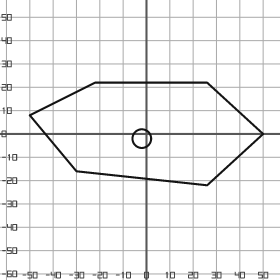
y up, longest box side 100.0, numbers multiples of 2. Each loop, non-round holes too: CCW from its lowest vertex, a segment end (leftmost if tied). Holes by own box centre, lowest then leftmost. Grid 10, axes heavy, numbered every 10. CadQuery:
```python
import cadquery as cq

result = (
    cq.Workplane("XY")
    .moveTo(26.0, -22.0)
    .lineTo(50.0, 0.0)
    .lineTo(26.0, 22.0)
    .lineTo(-22.0, 22.0)
    .lineTo(-50.0, 8.0)
    .lineTo(-30.0, -16.0)
    .close()
    .moveTo(-2.0, -2.0)
    .circle(4.0)
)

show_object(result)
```